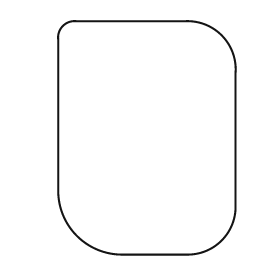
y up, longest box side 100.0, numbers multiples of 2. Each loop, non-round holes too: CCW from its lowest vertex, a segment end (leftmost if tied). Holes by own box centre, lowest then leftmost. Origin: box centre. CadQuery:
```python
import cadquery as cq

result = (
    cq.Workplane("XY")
    .moveTo(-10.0, -50.0)
    .lineTo(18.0, -50.0)
    .threePointArc((32.0, -44.0), (38.0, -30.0))
    .lineTo(38.0, 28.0)
    .threePointArc((32.0, 44.0), (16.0, 50.0))
    .lineTo(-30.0, 50.0)
    .threePointArc((-36.0, 48.0), (-38.0, 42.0))
    .lineTo(-38.0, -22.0)
    .threePointArc((-30.0, -42.0), (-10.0, -50.0))
    .close()
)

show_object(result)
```